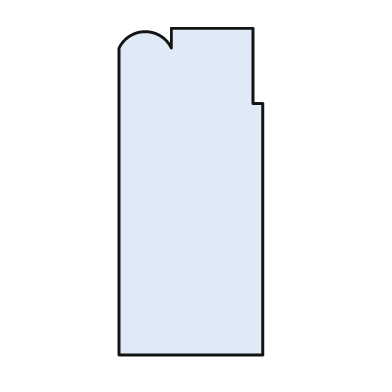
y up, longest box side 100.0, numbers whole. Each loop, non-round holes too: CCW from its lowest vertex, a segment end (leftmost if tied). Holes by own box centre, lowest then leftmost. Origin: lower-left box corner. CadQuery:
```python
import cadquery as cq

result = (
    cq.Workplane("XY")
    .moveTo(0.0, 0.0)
    .lineTo(44.0, 0.0)
    .lineTo(44.0, 77.0)
    .lineTo(41.0, 77.0)
    .lineTo(41.0, 100.0)
    .lineTo(16.0, 100.0)
    .lineTo(16.0, 94.0)
    .threePointArc((8.0, 99.0), (0.0, 94.0))
    .close()
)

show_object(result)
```